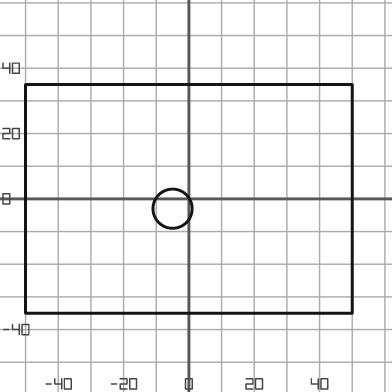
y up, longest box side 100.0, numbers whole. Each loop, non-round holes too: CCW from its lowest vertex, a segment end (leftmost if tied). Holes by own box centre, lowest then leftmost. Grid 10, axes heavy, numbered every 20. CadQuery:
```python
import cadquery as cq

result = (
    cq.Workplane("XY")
    .moveTo(-50.0, -35.0)
    .lineTo(50.0, -35.0)
    .lineTo(50.0, 35.0)
    .lineTo(-50.0, 35.0)
    .close()
    .moveTo(-5.0, -3.0)
    .circle(6.0)
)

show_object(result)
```